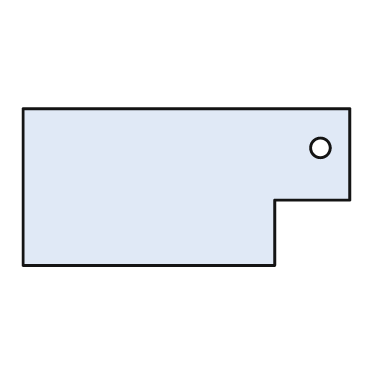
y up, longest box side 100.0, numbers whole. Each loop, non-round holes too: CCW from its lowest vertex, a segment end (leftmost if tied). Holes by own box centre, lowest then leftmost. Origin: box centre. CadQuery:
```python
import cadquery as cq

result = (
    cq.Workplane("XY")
    .moveTo(-50.0, -24.0)
    .lineTo(27.0, -24.0)
    .lineTo(27.0, -4.0)
    .lineTo(50.0, -4.0)
    .lineTo(50.0, 24.0)
    .lineTo(-50.0, 24.0)
    .close()
    .moveTo(41.0, 12.0)
    .circle(3.0)
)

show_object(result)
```